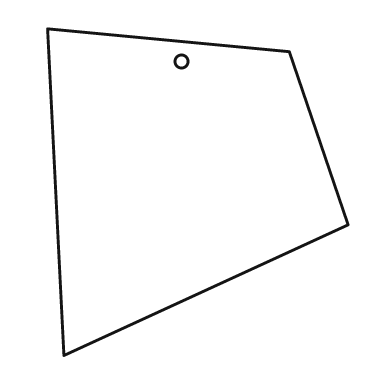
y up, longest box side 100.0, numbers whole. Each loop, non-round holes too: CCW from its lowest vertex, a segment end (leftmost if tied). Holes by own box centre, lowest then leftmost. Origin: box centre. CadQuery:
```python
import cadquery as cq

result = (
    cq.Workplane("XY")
    .moveTo(-41.0, -50.0)
    .lineTo(46.0, -10.0)
    .lineTo(28.0, 43.0)
    .lineTo(-46.0, 50.0)
    .close()
    .moveTo(-5.0, 40.0)
    .circle(2.0)
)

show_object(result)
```